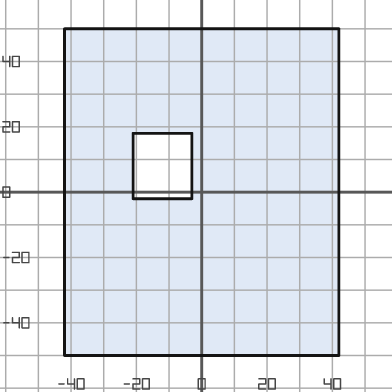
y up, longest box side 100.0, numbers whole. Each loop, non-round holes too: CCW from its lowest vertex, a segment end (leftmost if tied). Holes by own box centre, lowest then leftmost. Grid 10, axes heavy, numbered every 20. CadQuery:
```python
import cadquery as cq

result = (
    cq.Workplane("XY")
    .moveTo(-42.0, -50.0)
    .lineTo(42.0, -50.0)
    .lineTo(42.0, 50.0)
    .lineTo(-42.0, 50.0)
    .close()
    .moveTo(-21.0, -2.0)
    .lineTo(-3.0, -2.0)
    .lineTo(-3.0, 18.0)
    .lineTo(-21.0, 18.0)
    .close()
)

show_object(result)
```